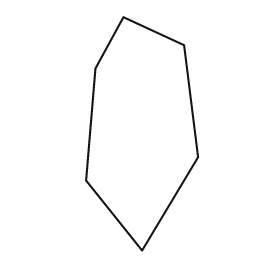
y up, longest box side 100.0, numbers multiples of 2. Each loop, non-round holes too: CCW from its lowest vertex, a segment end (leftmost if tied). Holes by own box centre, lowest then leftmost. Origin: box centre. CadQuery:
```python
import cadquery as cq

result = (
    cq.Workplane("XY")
    .moveTo(0.0, -50.0)
    .lineTo(24.0, -10.0)
    .lineTo(18.0, 38.0)
    .lineTo(-8.0, 50.0)
    .lineTo(-20.0, 28.0)
    .lineTo(-24.0, -20.0)
    .close()
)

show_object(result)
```